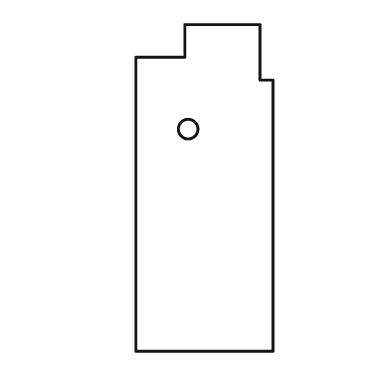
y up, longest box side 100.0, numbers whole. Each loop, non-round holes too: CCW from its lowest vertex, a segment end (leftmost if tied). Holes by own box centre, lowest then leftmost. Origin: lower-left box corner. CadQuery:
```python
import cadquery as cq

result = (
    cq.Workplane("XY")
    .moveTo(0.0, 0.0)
    .lineTo(42.0, 0.0)
    .lineTo(42.0, 83.0)
    .lineTo(38.0, 83.0)
    .lineTo(38.0, 100.0)
    .lineTo(15.0, 100.0)
    .lineTo(15.0, 90.0)
    .lineTo(0.0, 90.0)
    .close()
    .moveTo(16.0, 68.0)
    .circle(3.0)
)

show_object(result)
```